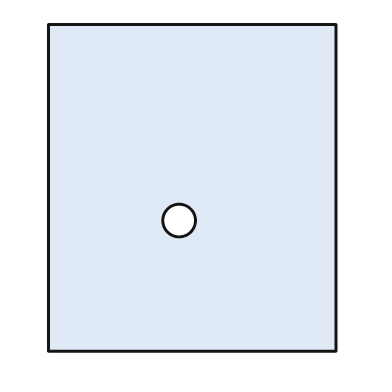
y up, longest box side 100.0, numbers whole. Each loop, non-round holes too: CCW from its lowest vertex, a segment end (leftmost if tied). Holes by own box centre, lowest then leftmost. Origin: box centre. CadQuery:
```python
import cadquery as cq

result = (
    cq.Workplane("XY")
    .moveTo(-44.0, -50.0)
    .lineTo(44.0, -50.0)
    .lineTo(44.0, 50.0)
    .lineTo(-44.0, 50.0)
    .close()
    .moveTo(-4.0, -10.0)
    .circle(5.0)
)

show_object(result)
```